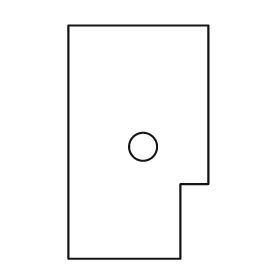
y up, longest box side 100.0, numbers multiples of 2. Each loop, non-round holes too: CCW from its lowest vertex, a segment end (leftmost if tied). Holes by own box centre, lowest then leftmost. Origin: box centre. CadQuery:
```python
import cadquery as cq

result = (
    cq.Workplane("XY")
    .moveTo(-30.0, -50.0)
    .lineTo(18.0, -50.0)
    .lineTo(18.0, -18.0)
    .lineTo(30.0, -18.0)
    .lineTo(30.0, 50.0)
    .lineTo(-30.0, 50.0)
    .close()
    .moveTo(2.0, -2.0)
    .circle(6.0)
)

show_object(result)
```